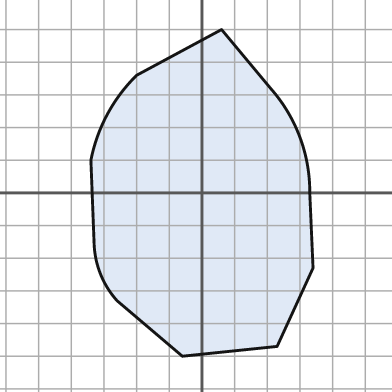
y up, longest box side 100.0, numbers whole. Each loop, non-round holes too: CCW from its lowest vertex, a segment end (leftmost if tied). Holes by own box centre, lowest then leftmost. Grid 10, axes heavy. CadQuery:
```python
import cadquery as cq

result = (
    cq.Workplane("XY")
    .moveTo(-6.0, -50.0)
    .lineTo(23.0, -47.0)
    .lineTo(34.0, -23.0)
    .lineTo(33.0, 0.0)
    .threePointArc((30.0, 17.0), (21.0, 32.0))
    .lineTo(6.0, 50.0)
    .lineTo(-20.0, 36.0)
    .threePointArc((-29.0, 24.0), (-34.0, 10.0))
    .lineTo(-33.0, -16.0)
    .threePointArc((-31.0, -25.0), (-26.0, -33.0))
    .close()
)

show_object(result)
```